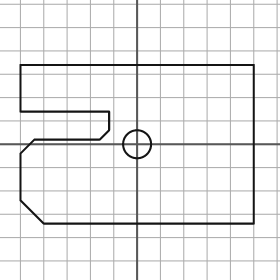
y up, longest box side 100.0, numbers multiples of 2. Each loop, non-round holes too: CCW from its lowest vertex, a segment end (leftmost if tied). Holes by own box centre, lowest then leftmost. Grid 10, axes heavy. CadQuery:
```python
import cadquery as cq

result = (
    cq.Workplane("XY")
    .moveTo(-40.0, -34.0)
    .lineTo(50.0, -34.0)
    .lineTo(50.0, 34.0)
    .lineTo(-50.0, 34.0)
    .lineTo(-50.0, 14.0)
    .lineTo(-12.0, 14.0)
    .lineTo(-12.0, 6.0)
    .lineTo(-16.0, 2.0)
    .lineTo(-44.0, 2.0)
    .lineTo(-50.0, -4.0)
    .lineTo(-50.0, -24.0)
    .close()
    .moveTo(0.0, 0.0)
    .circle(6.0)
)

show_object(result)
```